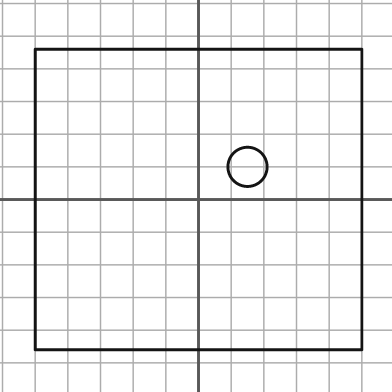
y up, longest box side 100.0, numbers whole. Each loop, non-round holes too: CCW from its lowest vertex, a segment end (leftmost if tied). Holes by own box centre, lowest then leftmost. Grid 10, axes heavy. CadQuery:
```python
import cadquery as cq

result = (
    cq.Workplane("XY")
    .moveTo(-50.0, -46.0)
    .lineTo(50.0, -46.0)
    .lineTo(50.0, 46.0)
    .lineTo(-50.0, 46.0)
    .close()
    .moveTo(15.0, 10.0)
    .circle(6.0)
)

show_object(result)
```